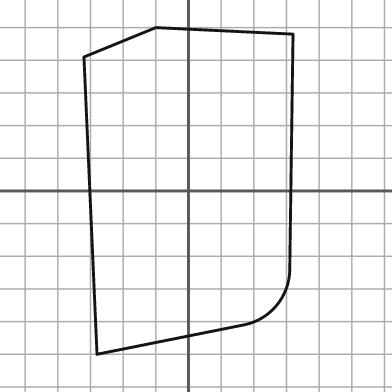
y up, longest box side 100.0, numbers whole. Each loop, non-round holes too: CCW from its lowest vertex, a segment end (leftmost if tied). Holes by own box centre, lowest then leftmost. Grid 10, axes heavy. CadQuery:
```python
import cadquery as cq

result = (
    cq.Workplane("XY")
    .moveTo(-28.0, -50.0)
    .lineTo(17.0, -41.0)
    .threePointArc((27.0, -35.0), (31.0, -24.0))
    .lineTo(32.0, 48.0)
    .lineTo(-10.0, 50.0)
    .lineTo(-32.0, 41.0)
    .close()
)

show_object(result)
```